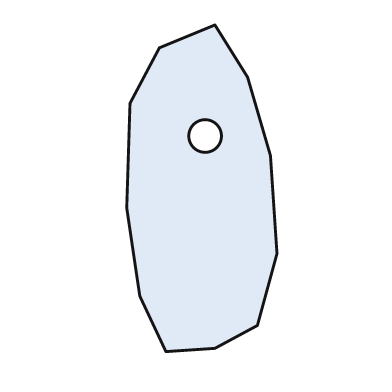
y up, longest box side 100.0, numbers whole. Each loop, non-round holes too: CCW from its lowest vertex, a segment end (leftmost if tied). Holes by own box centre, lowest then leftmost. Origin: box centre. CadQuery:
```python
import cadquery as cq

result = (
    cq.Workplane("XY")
    .moveTo(-11.0, -50.0)
    .lineTo(4.0, -49.0)
    .lineTo(17.0, -42.0)
    .lineTo(23.0, -20.0)
    .lineTo(21.0, 10.0)
    .lineTo(14.0, 34.0)
    .lineTo(4.0, 50.0)
    .lineTo(-13.0, 43.0)
    .lineTo(-22.0, 26.0)
    .lineTo(-23.0, -6.0)
    .lineTo(-19.0, -33.0)
    .close()
    .moveTo(1.0, 16.0)
    .circle(5.0)
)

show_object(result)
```